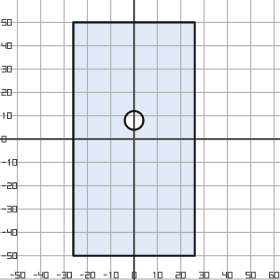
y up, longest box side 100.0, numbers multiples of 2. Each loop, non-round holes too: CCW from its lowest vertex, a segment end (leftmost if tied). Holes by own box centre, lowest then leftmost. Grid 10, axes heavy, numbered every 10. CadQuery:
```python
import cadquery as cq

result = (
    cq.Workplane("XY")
    .moveTo(-26.0, -50.0)
    .lineTo(26.0, -50.0)
    .lineTo(26.0, 50.0)
    .lineTo(-26.0, 50.0)
    .close()
    .moveTo(0.0, 8.0)
    .circle(4.0)
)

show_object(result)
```